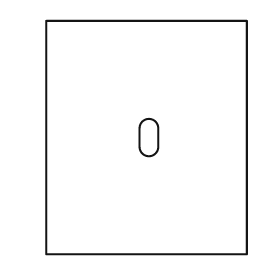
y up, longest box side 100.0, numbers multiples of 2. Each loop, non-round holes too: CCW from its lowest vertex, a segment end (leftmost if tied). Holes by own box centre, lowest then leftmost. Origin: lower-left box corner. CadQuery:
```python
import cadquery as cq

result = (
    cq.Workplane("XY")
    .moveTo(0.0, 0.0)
    .lineTo(86.0, 0.0)
    .lineTo(86.0, 100.0)
    .lineTo(0.0, 100.0)
    .close()
    .moveTo(40.0, 46.0)
    .threePointArc((44.0, 42.0), (48.0, 46.0))
    .lineTo(48.0, 54.0)
    .threePointArc((44.0, 58.0), (40.0, 54.0))
    .close()
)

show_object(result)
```